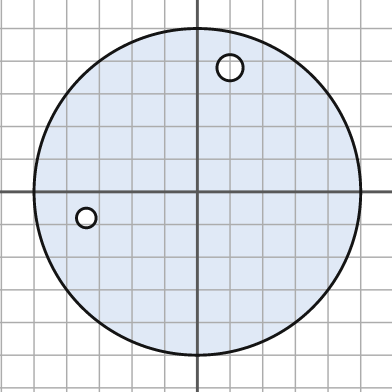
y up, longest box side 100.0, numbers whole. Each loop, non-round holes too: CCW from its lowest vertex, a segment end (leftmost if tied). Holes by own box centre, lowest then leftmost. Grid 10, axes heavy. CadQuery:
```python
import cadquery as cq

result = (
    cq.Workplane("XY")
    .moveTo(0.0, 0.0)
    .circle(50.0)
    .moveTo(-34.0, -8.0)
    .circle(3.0)
    .moveTo(10.0, 38.0)
    .circle(4.0)
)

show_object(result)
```